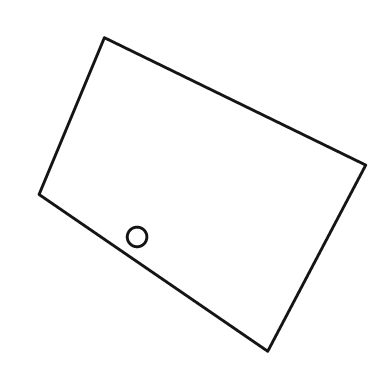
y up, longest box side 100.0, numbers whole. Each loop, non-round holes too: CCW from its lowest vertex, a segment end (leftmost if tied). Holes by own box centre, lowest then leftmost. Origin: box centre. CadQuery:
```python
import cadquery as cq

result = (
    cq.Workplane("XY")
    .moveTo(20.0, -48.0)
    .lineTo(50.0, 9.0)
    .lineTo(-30.0, 48.0)
    .lineTo(-50.0, 0.0)
    .close()
    .moveTo(-20.0, -13.0)
    .circle(3.0)
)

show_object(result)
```